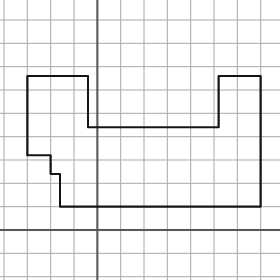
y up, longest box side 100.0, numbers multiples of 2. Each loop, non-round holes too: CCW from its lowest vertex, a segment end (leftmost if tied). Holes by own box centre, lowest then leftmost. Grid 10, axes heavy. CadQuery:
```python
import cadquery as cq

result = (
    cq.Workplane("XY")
    .moveTo(-16.0, 10.0)
    .lineTo(70.0, 10.0)
    .lineTo(70.0, 66.0)
    .lineTo(52.0, 66.0)
    .lineTo(52.0, 44.0)
    .lineTo(-4.0, 44.0)
    .lineTo(-4.0, 66.0)
    .lineTo(-30.0, 66.0)
    .lineTo(-30.0, 32.0)
    .lineTo(-20.0, 32.0)
    .lineTo(-20.0, 24.0)
    .lineTo(-16.0, 24.0)
    .close()
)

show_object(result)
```